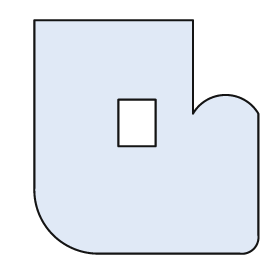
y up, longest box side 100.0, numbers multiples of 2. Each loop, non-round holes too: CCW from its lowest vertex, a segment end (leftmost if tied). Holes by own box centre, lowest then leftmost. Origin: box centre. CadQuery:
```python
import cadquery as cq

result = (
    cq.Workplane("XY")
    .moveTo(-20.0, -50.0)
    .lineTo(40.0, -50.0)
    .threePointArc((46.0, -48.0), (48.0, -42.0))
    .lineTo(48.0, 10.0)
    .threePointArc((34.0, 18.0), (20.0, 10.0))
    .lineTo(20.0, 50.0)
    .lineTo(-48.0, 50.0)
    .lineTo(-48.0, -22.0)
    .threePointArc((-40.0, -42.0), (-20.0, -50.0))
    .close()
    .moveTo(-12.0, -4.0)
    .lineTo(4.0, -4.0)
    .lineTo(4.0, 16.0)
    .lineTo(-12.0, 16.0)
    .close()
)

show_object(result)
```